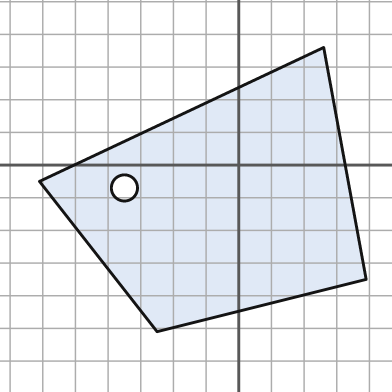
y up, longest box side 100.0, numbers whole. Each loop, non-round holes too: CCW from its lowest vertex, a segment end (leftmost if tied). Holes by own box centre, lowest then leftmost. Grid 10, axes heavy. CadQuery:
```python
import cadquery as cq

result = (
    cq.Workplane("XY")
    .moveTo(-25.0, -51.0)
    .lineTo(39.0, -35.0)
    .lineTo(26.0, 36.0)
    .lineTo(-61.0, -5.0)
    .close()
    .moveTo(-35.0, -7.0)
    .circle(4.0)
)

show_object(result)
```